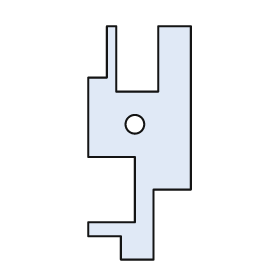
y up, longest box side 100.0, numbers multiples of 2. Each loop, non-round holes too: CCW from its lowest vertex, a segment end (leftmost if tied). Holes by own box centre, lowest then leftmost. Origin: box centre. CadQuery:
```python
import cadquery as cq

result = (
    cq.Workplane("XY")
    .moveTo(-8.0, -50.0)
    .lineTo(6.0, -50.0)
    .lineTo(6.0, -20.0)
    .lineTo(22.0, -20.0)
    .lineTo(22.0, 50.0)
    .lineTo(8.0, 50.0)
    .lineTo(8.0, 22.0)
    .lineTo(-10.0, 22.0)
    .lineTo(-10.0, 50.0)
    .lineTo(-14.0, 50.0)
    .lineTo(-14.0, 28.0)
    .lineTo(-22.0, 28.0)
    .lineTo(-22.0, -6.0)
    .lineTo(-2.0, -6.0)
    .lineTo(-2.0, -34.0)
    .lineTo(-22.0, -34.0)
    .lineTo(-22.0, -40.0)
    .lineTo(-8.0, -40.0)
    .close()
    .moveTo(-2.0, 8.0)
    .circle(4.0)
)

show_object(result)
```